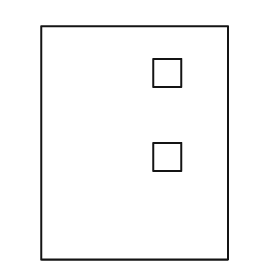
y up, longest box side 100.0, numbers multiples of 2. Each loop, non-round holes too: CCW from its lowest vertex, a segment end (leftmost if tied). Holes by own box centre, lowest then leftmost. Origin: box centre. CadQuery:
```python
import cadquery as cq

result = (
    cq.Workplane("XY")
    .moveTo(-40.0, -50.0)
    .lineTo(40.0, -50.0)
    .lineTo(40.0, 50.0)
    .lineTo(-40.0, 50.0)
    .close()
    .moveTo(8.0, -12.0)
    .lineTo(20.0, -12.0)
    .lineTo(20.0, 0.0)
    .lineTo(8.0, 0.0)
    .close()
    .moveTo(8.0, 24.0)
    .lineTo(20.0, 24.0)
    .lineTo(20.0, 36.0)
    .lineTo(8.0, 36.0)
    .close()
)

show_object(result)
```